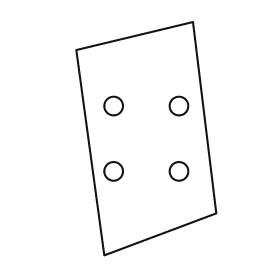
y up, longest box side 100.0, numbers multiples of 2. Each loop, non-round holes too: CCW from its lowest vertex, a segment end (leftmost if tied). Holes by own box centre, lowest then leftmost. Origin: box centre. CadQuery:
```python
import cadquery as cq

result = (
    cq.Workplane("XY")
    .moveTo(-18.0, -50.0)
    .lineTo(30.0, -32.0)
    .lineTo(20.0, 50.0)
    .lineTo(-30.0, 38.0)
    .close()
    .moveTo(-14.0, -14.0)
    .circle(4.0)
    .moveTo(14.0, -14.0)
    .circle(4.0)
    .moveTo(-14.0, 14.0)
    .circle(4.0)
    .moveTo(14.0, 14.0)
    .circle(4.0)
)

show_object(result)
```